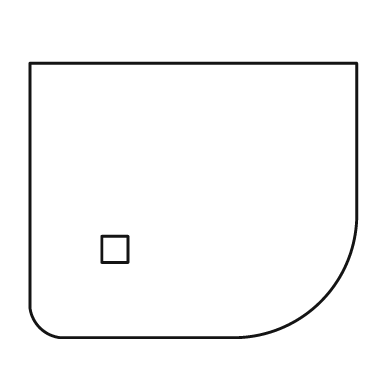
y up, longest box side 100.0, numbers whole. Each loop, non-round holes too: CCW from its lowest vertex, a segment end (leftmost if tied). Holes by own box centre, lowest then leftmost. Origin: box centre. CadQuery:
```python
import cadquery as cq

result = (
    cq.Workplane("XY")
    .moveTo(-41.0, -42.0)
    .lineTo(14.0, -42.0)
    .threePointArc((39.0, -31.0), (50.0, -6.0))
    .lineTo(50.0, 42.0)
    .lineTo(-50.0, 42.0)
    .lineTo(-50.0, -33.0)
    .threePointArc((-47.0, -39.0), (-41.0, -42.0))
    .close()
    .moveTo(-28.0, -19.0)
    .lineTo(-20.0, -19.0)
    .lineTo(-20.0, -11.0)
    .lineTo(-28.0, -11.0)
    .close()
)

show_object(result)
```